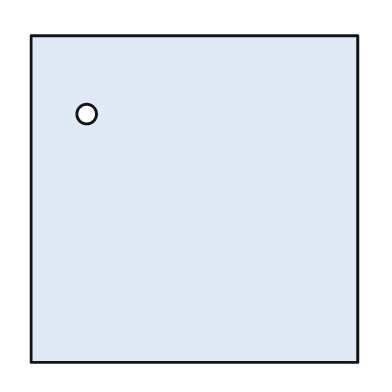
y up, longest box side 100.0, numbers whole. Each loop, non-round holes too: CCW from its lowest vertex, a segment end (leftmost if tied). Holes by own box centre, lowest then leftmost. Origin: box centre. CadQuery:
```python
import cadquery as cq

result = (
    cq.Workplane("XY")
    .moveTo(-50.0, -50.0)
    .lineTo(50.0, -50.0)
    .lineTo(50.0, 50.0)
    .lineTo(-50.0, 50.0)
    .close()
    .moveTo(-33.0, 26.0)
    .circle(3.0)
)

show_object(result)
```